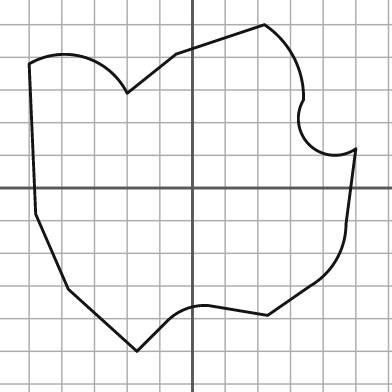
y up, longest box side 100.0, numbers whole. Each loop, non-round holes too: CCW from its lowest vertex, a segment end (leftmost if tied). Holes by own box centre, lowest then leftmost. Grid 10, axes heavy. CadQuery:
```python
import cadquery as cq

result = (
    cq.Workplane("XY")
    .moveTo(-17.0, -50.0)
    .lineTo(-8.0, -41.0)
    .threePointArc((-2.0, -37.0), (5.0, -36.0))
    .lineTo(23.0, -39.0)
    .lineTo(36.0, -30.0)
    .threePointArc((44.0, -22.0), (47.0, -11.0))
    .lineTo(50.0, 12.0)
    .threePointArc((36.0, 13.0), (34.0, 27.0))
    .threePointArc((31.0, 40.0), (22.0, 50.0))
    .lineTo(-5.0, 41.0)
    .lineTo(-20.0, 29.0)
    .threePointArc((-33.0, 40.0), (-50.0, 38.0))
    .lineTo(-48.0, -8.0)
    .lineTo(-38.0, -31.0)
    .close()
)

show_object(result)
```